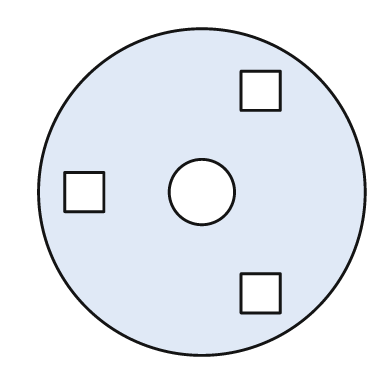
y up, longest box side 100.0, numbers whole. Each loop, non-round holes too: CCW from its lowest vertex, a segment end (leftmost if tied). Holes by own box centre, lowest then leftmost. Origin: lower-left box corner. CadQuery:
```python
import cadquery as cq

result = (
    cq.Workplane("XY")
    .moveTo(50.0, 50.0)
    .circle(50.0)
    .moveTo(62.0, 13.0)
    .lineTo(74.0, 13.0)
    .lineTo(74.0, 25.0)
    .lineTo(62.0, 25.0)
    .close()
    .moveTo(8.0, 44.0)
    .lineTo(20.0, 44.0)
    .lineTo(20.0, 56.0)
    .lineTo(8.0, 56.0)
    .close()
    .moveTo(50.0, 50.0)
    .circle(10.0)
    .moveTo(62.0, 75.0)
    .lineTo(74.0, 75.0)
    .lineTo(74.0, 87.0)
    .lineTo(62.0, 87.0)
    .close()
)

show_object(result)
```